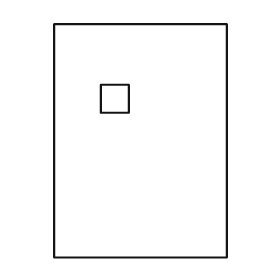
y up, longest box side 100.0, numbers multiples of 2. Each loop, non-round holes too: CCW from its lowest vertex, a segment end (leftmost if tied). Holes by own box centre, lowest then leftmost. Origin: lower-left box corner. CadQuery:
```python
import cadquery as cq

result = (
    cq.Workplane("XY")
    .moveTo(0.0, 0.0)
    .lineTo(74.0, 0.0)
    .lineTo(74.0, 100.0)
    .lineTo(0.0, 100.0)
    .close()
    .moveTo(20.0, 62.0)
    .lineTo(32.0, 62.0)
    .lineTo(32.0, 74.0)
    .lineTo(20.0, 74.0)
    .close()
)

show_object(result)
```